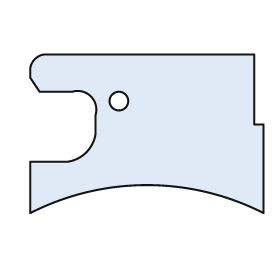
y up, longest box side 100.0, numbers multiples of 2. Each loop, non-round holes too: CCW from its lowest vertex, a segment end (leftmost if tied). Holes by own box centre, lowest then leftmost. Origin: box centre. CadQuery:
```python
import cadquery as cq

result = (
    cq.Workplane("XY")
    .moveTo(-50.0, -34.0)
    .threePointArc((0.0, -22.0), (50.0, -34.0))
    .lineTo(50.0, 4.0)
    .lineTo(46.0, 4.0)
    .lineTo(46.0, 34.0)
    .lineTo(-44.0, 34.0)
    .threePointArc((-48.0, 32.0), (-50.0, 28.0))
    .lineTo(-50.0, 24.0)
    .lineTo(-46.0, 18.0)
    .lineTo(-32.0, 18.0)
    .threePointArc((-24.0, 16.0), (-22.0, 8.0))
    .lineTo(-22.0, 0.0)
    .threePointArc((-26.0, -8.0), (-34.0, -12.0))
    .lineTo(-50.0, -12.0)
    .close()
    .moveTo(-12.0, 14.0)
    .circle(4.0)
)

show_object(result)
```